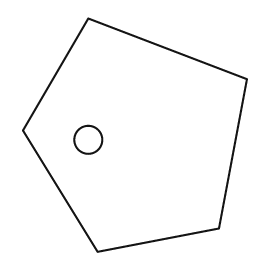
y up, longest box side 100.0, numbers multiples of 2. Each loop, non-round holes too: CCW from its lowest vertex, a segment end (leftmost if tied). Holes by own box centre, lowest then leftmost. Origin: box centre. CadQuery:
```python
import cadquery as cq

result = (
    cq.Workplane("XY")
    .moveTo(-16.0, -50.0)
    .lineTo(36.0, -40.0)
    .lineTo(48.0, 24.0)
    .lineTo(-20.0, 50.0)
    .lineTo(-48.0, 2.0)
    .close()
    .moveTo(-20.0, -2.0)
    .circle(6.0)
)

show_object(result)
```